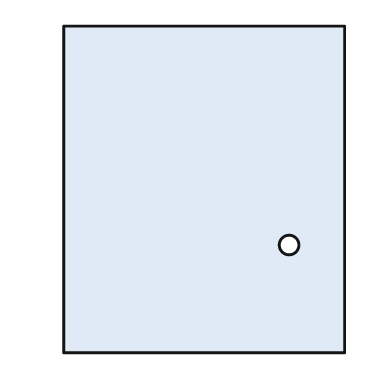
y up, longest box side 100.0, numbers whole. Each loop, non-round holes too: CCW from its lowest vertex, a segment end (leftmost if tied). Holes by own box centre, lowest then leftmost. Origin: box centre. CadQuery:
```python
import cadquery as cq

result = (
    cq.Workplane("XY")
    .moveTo(-43.0, -50.0)
    .lineTo(43.0, -50.0)
    .lineTo(43.0, 50.0)
    .lineTo(-43.0, 50.0)
    .close()
    .moveTo(26.0, -17.0)
    .circle(3.0)
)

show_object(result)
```